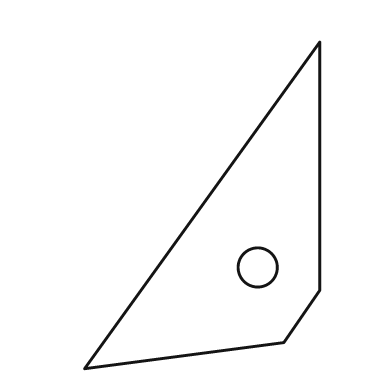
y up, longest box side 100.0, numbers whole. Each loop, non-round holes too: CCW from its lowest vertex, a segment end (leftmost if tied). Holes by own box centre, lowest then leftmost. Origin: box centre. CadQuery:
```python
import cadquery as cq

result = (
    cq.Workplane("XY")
    .moveTo(-36.0, -50.0)
    .lineTo(25.0, -42.0)
    .lineTo(36.0, -26.0)
    .lineTo(36.0, 50.0)
    .close()
    .moveTo(17.0, -19.0)
    .circle(6.0)
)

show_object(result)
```